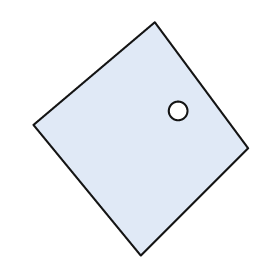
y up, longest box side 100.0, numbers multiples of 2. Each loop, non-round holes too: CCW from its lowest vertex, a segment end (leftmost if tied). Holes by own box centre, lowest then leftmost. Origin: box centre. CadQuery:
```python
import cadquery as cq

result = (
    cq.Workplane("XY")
    .moveTo(0.0, -50.0)
    .lineTo(46.0, -4.0)
    .lineTo(6.0, 50.0)
    .lineTo(-46.0, 6.0)
    .close()
    .moveTo(16.0, 12.0)
    .circle(4.0)
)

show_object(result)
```